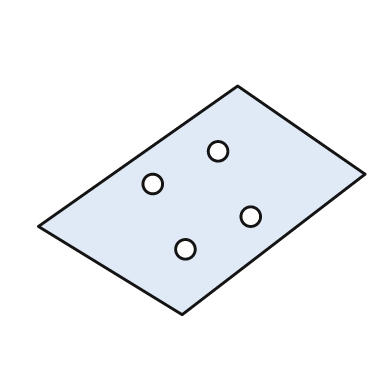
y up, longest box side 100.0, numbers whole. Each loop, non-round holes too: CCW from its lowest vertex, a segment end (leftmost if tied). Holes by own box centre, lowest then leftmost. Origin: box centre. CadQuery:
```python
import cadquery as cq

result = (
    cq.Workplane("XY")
    .moveTo(-6.0, -35.0)
    .lineTo(50.0, 8.0)
    .lineTo(11.0, 35.0)
    .lineTo(-50.0, -8.0)
    .close()
    .moveTo(-5.0, -15.0)
    .circle(3.0)
    .moveTo(15.0, -5.0)
    .circle(3.0)
    .moveTo(-15.0, 5.0)
    .circle(3.0)
    .moveTo(5.0, 15.0)
    .circle(3.0)
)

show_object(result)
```